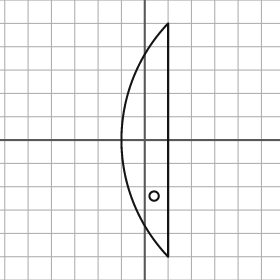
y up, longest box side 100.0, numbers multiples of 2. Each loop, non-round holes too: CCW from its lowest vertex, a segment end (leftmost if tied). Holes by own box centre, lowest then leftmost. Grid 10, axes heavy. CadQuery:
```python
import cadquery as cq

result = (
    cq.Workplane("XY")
    .moveTo(10.0, -50.0)
    .lineTo(10.0, 50.0)
    .threePointArc((-10.0, 0.0), (10.0, -50.0))
    .close()
    .moveTo(4.0, -24.0)
    .circle(2.0)
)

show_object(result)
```